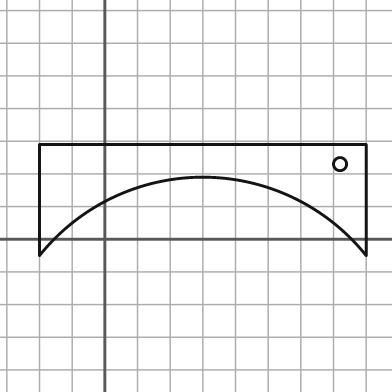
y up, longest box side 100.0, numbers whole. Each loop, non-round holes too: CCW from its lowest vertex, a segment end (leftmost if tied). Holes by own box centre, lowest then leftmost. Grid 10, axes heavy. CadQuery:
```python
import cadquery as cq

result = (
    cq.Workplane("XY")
    .moveTo(-20.0, -5.0)
    .threePointArc((30.0, 19.0), (80.0, -5.0))
    .lineTo(80.0, 29.0)
    .lineTo(-20.0, 29.0)
    .close()
    .moveTo(72.0, 23.0)
    .circle(2.0)
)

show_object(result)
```